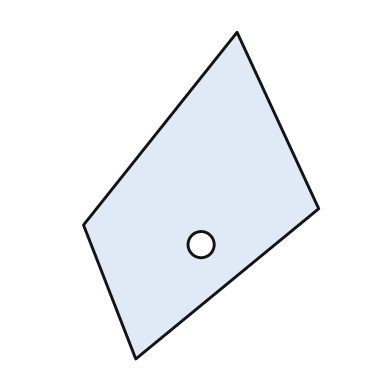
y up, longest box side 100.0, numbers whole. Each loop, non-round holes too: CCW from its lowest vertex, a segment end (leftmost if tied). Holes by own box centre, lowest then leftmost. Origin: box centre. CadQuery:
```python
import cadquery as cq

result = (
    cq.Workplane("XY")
    .moveTo(-20.0, -50.0)
    .lineTo(36.0, -4.0)
    .lineTo(11.0, 50.0)
    .lineTo(-36.0, -9.0)
    .close()
    .moveTo(0.0, -15.0)
    .circle(4.0)
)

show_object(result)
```